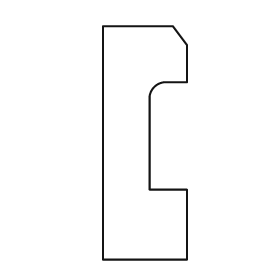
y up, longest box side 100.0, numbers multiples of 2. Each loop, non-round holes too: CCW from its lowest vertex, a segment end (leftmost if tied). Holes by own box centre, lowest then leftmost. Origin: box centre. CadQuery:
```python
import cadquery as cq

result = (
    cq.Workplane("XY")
    .moveTo(-18.0, -50.0)
    .lineTo(18.0, -50.0)
    .lineTo(18.0, -20.0)
    .lineTo(2.0, -20.0)
    .lineTo(2.0, 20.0)
    .threePointArc((4.0, 24.0), (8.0, 26.0))
    .lineTo(18.0, 26.0)
    .lineTo(18.0, 42.0)
    .lineTo(12.0, 50.0)
    .lineTo(-18.0, 50.0)
    .close()
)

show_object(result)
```